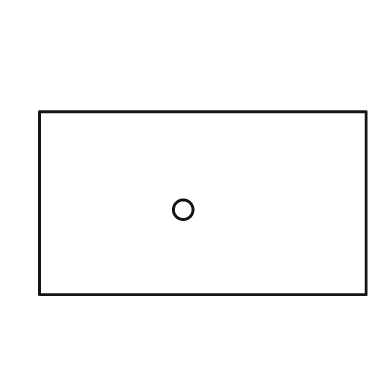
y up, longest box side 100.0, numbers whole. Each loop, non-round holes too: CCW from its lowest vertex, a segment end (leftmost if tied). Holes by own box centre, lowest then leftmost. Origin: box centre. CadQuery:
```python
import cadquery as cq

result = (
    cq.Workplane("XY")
    .moveTo(-50.0, -28.0)
    .lineTo(50.0, -28.0)
    .lineTo(50.0, 28.0)
    .lineTo(-50.0, 28.0)
    .close()
    .moveTo(-6.0, -2.0)
    .circle(3.0)
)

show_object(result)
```